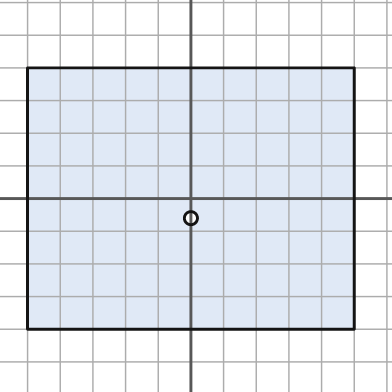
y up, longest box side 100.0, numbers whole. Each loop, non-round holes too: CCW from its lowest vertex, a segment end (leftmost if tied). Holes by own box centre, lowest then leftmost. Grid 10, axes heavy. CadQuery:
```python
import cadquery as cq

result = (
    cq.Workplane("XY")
    .moveTo(-50.0, -40.0)
    .lineTo(50.0, -40.0)
    .lineTo(50.0, 40.0)
    .lineTo(-50.0, 40.0)
    .close()
    .moveTo(0.0, -6.0)
    .circle(2.0)
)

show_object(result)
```